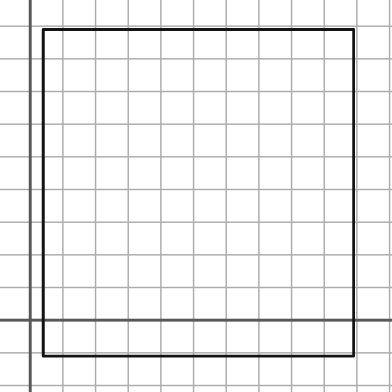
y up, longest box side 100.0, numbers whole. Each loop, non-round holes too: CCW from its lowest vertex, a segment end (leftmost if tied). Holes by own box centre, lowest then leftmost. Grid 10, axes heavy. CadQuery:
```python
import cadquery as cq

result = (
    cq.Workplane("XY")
    .moveTo(4.0, -11.0)
    .lineTo(99.0, -11.0)
    .lineTo(99.0, 89.0)
    .lineTo(4.0, 89.0)
    .close()
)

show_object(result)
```